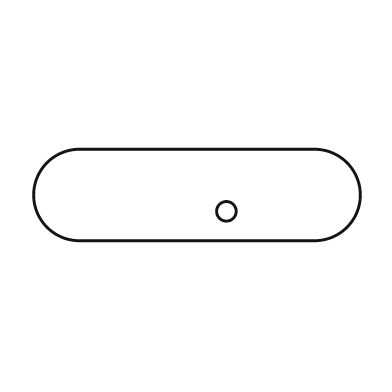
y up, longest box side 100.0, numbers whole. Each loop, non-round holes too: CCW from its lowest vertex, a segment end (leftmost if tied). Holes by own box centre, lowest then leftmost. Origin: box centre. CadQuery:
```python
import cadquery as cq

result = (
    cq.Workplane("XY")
    .moveTo(-36.0, -14.0)
    .lineTo(36.0, -14.0)
    .threePointArc((50.0, 0.0), (36.0, 14.0))
    .lineTo(-36.0, 14.0)
    .threePointArc((-50.0, 0.0), (-36.0, -14.0))
    .close()
    .moveTo(9.0, -5.0)
    .circle(3.0)
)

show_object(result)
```